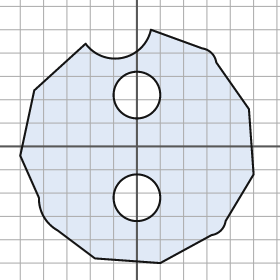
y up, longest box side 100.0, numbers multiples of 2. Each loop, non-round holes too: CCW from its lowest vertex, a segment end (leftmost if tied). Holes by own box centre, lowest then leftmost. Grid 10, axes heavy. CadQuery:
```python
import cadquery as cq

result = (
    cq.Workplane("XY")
    .moveTo(10.0, -50.0)
    .lineTo(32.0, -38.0)
    .threePointArc((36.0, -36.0), (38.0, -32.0))
    .lineTo(50.0, -12.0)
    .lineTo(48.0, 16.0)
    .lineTo(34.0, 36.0)
    .threePointArc((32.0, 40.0), (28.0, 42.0))
    .lineTo(6.0, 50.0)
    .threePointArc((-6.0, 38.0), (-22.0, 44.0))
    .lineTo(-44.0, 24.0)
    .lineTo(-50.0, -4.0)
    .lineTo(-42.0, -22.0)
    .threePointArc((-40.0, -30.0), (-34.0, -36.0))
    .lineTo(-18.0, -48.0)
    .close()
    .moveTo(0.0, -22.0)
    .circle(10.0)
    .moveTo(0.0, 22.0)
    .circle(10.0)
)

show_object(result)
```